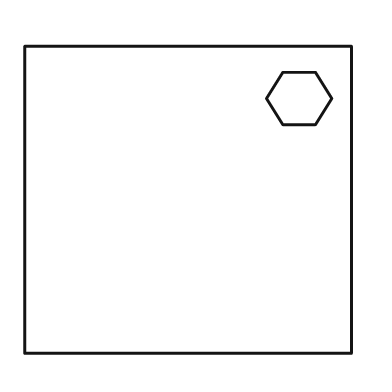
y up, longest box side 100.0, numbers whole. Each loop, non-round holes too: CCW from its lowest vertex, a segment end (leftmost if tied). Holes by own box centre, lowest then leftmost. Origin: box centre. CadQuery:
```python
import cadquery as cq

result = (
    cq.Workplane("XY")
    .moveTo(-50.0, -47.0)
    .lineTo(50.0, -47.0)
    .lineTo(50.0, 47.0)
    .lineTo(-50.0, 47.0)
    .close()
    .moveTo(29.0, 23.0)
    .lineTo(39.0, 23.0)
    .lineTo(44.0, 31.0)
    .lineTo(39.0, 39.0)
    .lineTo(29.0, 39.0)
    .lineTo(24.0, 31.0)
    .close()
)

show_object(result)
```